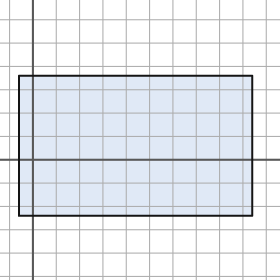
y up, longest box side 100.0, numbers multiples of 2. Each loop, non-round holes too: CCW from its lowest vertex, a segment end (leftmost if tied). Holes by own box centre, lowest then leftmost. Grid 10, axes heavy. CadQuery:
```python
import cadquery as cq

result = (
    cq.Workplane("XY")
    .moveTo(-6.0, -24.0)
    .lineTo(94.0, -24.0)
    .lineTo(94.0, 36.0)
    .lineTo(-6.0, 36.0)
    .close()
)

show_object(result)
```